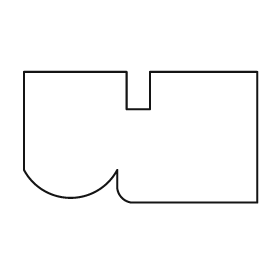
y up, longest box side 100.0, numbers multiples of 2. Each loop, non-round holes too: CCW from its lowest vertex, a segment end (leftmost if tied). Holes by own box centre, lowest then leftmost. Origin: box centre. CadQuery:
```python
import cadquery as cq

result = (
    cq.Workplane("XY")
    .moveTo(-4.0, -28.0)
    .lineTo(50.0, -28.0)
    .lineTo(50.0, 28.0)
    .lineTo(4.0, 28.0)
    .lineTo(4.0, 12.0)
    .lineTo(-6.0, 12.0)
    .lineTo(-6.0, 28.0)
    .lineTo(-50.0, 28.0)
    .lineTo(-50.0, -14.0)
    .threePointArc((-30.0, -26.0), (-10.0, -14.0))
    .lineTo(-10.0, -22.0)
    .threePointArc((-8.0, -26.0), (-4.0, -28.0))
    .close()
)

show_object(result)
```